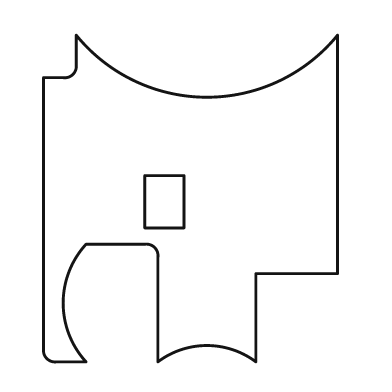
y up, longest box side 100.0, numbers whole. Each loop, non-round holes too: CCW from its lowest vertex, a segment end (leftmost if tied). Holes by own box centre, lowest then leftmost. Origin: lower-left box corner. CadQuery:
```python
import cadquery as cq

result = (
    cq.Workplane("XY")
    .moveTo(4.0, 0.0)
    .lineTo(13.0, 0.0)
    .threePointArc((6.0, 18.0), (13.0, 36.0))
    .lineTo(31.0, 36.0)
    .threePointArc((34.0, 35.0), (35.0, 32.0))
    .lineTo(35.0, 0.0)
    .threePointArc((50.0, 5.0), (65.0, 0.0))
    .lineTo(65.0, 27.0)
    .lineTo(90.0, 27.0)
    .lineTo(90.0, 100.0)
    .threePointArc((50.0, 81.0), (10.0, 100.0))
    .lineTo(10.0, 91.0)
    .threePointArc((9.0, 88.0), (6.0, 87.0))
    .lineTo(0.0, 87.0)
    .lineTo(0.0, 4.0)
    .threePointArc((1.0, 1.0), (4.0, 0.0))
    .close()
    .moveTo(31.0, 41.0)
    .lineTo(43.0, 41.0)
    .lineTo(43.0, 57.0)
    .lineTo(31.0, 57.0)
    .close()
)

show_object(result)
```